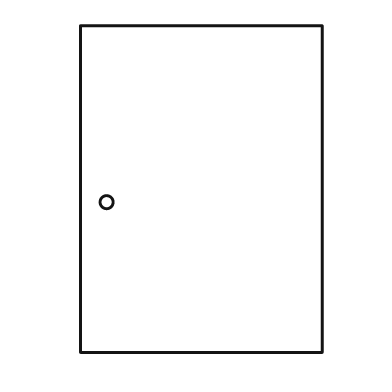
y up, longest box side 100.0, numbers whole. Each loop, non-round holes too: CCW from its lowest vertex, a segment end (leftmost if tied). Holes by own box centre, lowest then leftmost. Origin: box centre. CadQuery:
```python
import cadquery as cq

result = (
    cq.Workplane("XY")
    .moveTo(-37.0, -50.0)
    .lineTo(37.0, -50.0)
    .lineTo(37.0, 50.0)
    .lineTo(-37.0, 50.0)
    .close()
    .moveTo(-29.0, -4.0)
    .circle(2.0)
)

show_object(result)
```